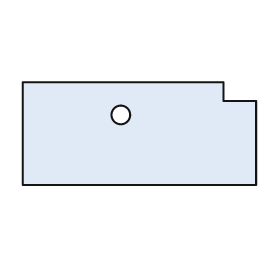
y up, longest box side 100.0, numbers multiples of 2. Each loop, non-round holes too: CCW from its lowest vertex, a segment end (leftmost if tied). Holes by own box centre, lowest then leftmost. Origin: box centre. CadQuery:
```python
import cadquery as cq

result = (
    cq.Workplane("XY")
    .moveTo(-50.0, -22.0)
    .lineTo(50.0, -22.0)
    .lineTo(50.0, 14.0)
    .lineTo(36.0, 14.0)
    .lineTo(36.0, 22.0)
    .lineTo(-50.0, 22.0)
    .close()
    .moveTo(-8.0, 8.0)
    .circle(4.0)
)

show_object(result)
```